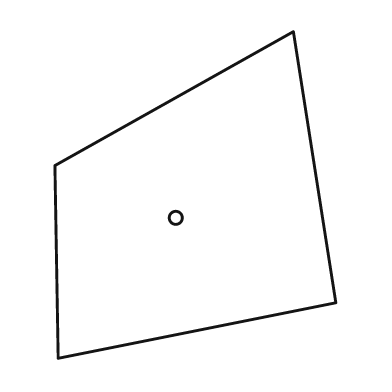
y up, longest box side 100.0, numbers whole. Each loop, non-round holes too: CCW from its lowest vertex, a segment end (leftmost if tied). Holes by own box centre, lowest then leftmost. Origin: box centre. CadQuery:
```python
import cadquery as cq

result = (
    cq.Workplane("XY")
    .moveTo(-42.0, -50.0)
    .lineTo(43.0, -33.0)
    .lineTo(30.0, 50.0)
    .lineTo(-43.0, 9.0)
    .close()
    .moveTo(-6.0, -7.0)
    .circle(2.0)
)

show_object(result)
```